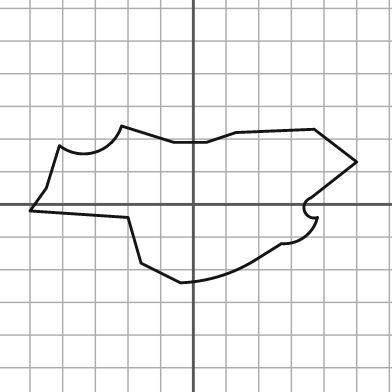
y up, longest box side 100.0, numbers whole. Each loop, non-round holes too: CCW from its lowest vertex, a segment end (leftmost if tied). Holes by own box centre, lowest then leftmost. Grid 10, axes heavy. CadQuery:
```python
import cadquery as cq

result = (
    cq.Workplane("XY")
    .moveTo(-4.0, -24.0)
    .threePointArc((8.0, -22.0), (19.0, -17.0))
    .lineTo(27.0, -12.0)
    .threePointArc((34.0, -10.0), (38.0, -4.0))
    .threePointArc((34.0, -2.0), (36.0, 2.0))
    .lineTo(50.0, 13.0)
    .lineTo(37.0, 23.0)
    .lineTo(13.0, 22.0)
    .lineTo(4.0, 19.0)
    .lineTo(-6.0, 19.0)
    .lineTo(-22.0, 24.0)
    .threePointArc((-30.0, 16.0), (-41.0, 18.0))
    .lineTo(-45.0, 5.0)
    .lineTo(-50.0, -2.0)
    .lineTo(-20.0, -4.0)
    .lineTo(-16.0, -18.0)
    .close()
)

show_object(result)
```